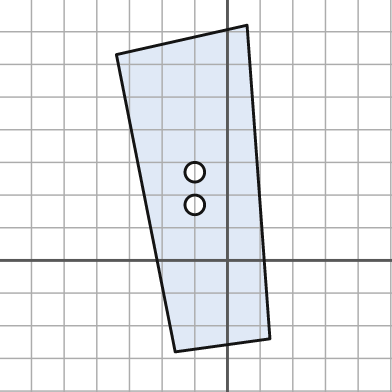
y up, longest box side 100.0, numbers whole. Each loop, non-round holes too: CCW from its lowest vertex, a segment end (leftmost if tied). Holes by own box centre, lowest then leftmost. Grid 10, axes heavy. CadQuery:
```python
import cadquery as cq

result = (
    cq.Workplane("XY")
    .moveTo(-16.0, -28.0)
    .lineTo(13.0, -24.0)
    .lineTo(6.0, 72.0)
    .lineTo(-34.0, 63.0)
    .close()
    .moveTo(-10.0, 17.0)
    .circle(3.0)
    .moveTo(-10.0, 27.0)
    .circle(3.0)
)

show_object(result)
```